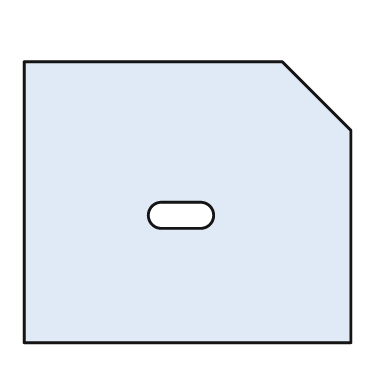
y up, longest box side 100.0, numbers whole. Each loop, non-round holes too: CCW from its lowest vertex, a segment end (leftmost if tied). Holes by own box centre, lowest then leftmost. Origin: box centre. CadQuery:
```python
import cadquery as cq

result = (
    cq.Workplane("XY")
    .moveTo(-50.0, -43.0)
    .lineTo(50.0, -43.0)
    .lineTo(50.0, 22.0)
    .lineTo(29.0, 43.0)
    .lineTo(-50.0, 43.0)
    .close()
    .moveTo(-8.0, -8.0)
    .lineTo(4.0, -8.0)
    .threePointArc((8.0, -4.0), (4.0, 0.0))
    .lineTo(-8.0, 0.0)
    .threePointArc((-12.0, -4.0), (-8.0, -8.0))
    .close()
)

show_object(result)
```